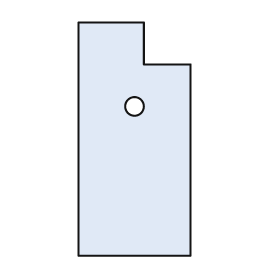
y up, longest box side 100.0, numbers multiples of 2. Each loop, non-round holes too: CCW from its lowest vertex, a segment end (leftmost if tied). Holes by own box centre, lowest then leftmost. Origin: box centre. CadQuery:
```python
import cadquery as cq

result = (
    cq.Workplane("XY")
    .moveTo(-24.0, -50.0)
    .lineTo(24.0, -50.0)
    .lineTo(24.0, 32.0)
    .lineTo(4.0, 32.0)
    .lineTo(4.0, 50.0)
    .lineTo(-24.0, 50.0)
    .close()
    .moveTo(0.0, 14.0)
    .circle(4.0)
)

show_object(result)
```